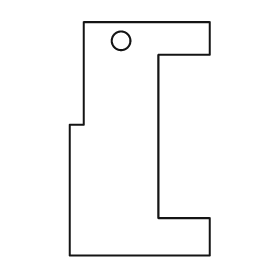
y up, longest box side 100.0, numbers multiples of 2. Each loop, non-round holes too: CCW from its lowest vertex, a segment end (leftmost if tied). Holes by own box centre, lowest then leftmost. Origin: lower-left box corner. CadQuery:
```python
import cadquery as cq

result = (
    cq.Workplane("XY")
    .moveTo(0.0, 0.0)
    .lineTo(60.0, 0.0)
    .lineTo(60.0, 16.0)
    .lineTo(38.0, 16.0)
    .lineTo(38.0, 86.0)
    .lineTo(60.0, 86.0)
    .lineTo(60.0, 100.0)
    .lineTo(6.0, 100.0)
    .lineTo(6.0, 56.0)
    .lineTo(0.0, 56.0)
    .close()
    .moveTo(22.0, 92.0)
    .circle(4.0)
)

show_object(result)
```